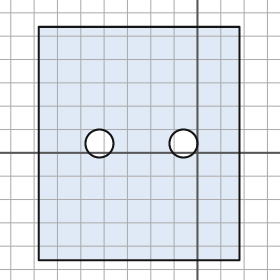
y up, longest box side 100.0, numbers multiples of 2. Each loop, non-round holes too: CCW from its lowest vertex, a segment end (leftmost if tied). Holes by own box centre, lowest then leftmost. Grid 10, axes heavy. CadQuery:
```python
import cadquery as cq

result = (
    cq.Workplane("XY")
    .moveTo(-68.0, -46.0)
    .lineTo(18.0, -46.0)
    .lineTo(18.0, 54.0)
    .lineTo(-68.0, 54.0)
    .close()
    .moveTo(-42.0, 4.0)
    .circle(6.0)
    .moveTo(-6.0, 4.0)
    .circle(6.0)
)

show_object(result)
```